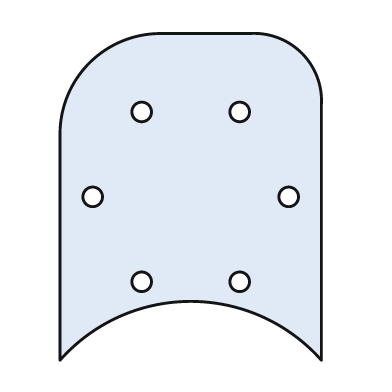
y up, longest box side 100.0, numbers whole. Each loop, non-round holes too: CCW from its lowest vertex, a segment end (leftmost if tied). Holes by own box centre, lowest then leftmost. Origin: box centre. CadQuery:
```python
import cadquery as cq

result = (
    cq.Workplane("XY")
    .moveTo(-40.0, -50.0)
    .threePointArc((0.0, -32.0), (40.0, -50.0))
    .lineTo(40.0, 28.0)
    .threePointArc((34.0, 44.0), (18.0, 50.0))
    .lineTo(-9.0, 50.0)
    .threePointArc((-31.0, 41.0), (-40.0, 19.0))
    .close()
    .moveTo(-15.0, -26.0)
    .circle(3.0)
    .moveTo(15.0, -26.0)
    .circle(3.0)
    .moveTo(-30.0, 0.0)
    .circle(3.0)
    .moveTo(30.0, 0.0)
    .circle(3.0)
    .moveTo(-15.0, 26.0)
    .circle(3.0)
    .moveTo(15.0, 26.0)
    .circle(3.0)
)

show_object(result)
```